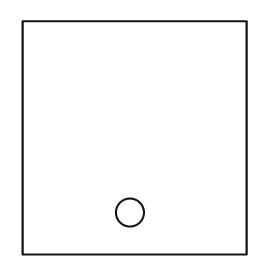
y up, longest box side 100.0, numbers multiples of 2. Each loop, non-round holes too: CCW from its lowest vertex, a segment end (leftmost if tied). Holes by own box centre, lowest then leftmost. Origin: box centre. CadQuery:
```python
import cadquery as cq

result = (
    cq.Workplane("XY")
    .moveTo(-48.0, -50.0)
    .lineTo(48.0, -50.0)
    .lineTo(48.0, 50.0)
    .lineTo(-48.0, 50.0)
    .close()
    .moveTo(-2.0, -32.0)
    .circle(6.0)
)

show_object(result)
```